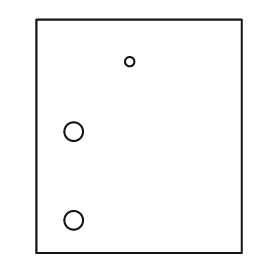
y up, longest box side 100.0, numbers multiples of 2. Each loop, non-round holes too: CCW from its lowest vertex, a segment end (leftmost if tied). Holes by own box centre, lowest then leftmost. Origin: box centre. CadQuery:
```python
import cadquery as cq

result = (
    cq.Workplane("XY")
    .moveTo(-44.0, -50.0)
    .lineTo(44.0, -50.0)
    .lineTo(44.0, 50.0)
    .lineTo(-44.0, 50.0)
    .close()
    .moveTo(-28.0, -36.0)
    .circle(4.0)
    .moveTo(-28.0, 2.0)
    .circle(4.0)
    .moveTo(-4.0, 32.0)
    .circle(2.0)
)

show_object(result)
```